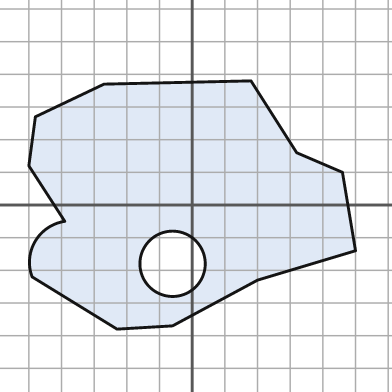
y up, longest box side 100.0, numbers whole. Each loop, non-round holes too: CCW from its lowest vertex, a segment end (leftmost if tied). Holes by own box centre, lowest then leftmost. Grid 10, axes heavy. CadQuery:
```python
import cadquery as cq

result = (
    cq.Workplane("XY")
    .moveTo(-23.0, -38.0)
    .lineTo(-6.0, -37.0)
    .lineTo(20.0, -23.0)
    .lineTo(50.0, -14.0)
    .lineTo(46.0, 10.0)
    .lineTo(32.0, 16.0)
    .lineTo(18.0, 38.0)
    .lineTo(-27.0, 37.0)
    .lineTo(-48.0, 27.0)
    .lineTo(-50.0, 12.0)
    .lineTo(-39.0, -5.0)
    .threePointArc((-48.0, -11.0), (-49.0, -22.0))
    .close()
    .moveTo(-6.0, -18.0)
    .circle(10.0)
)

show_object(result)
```